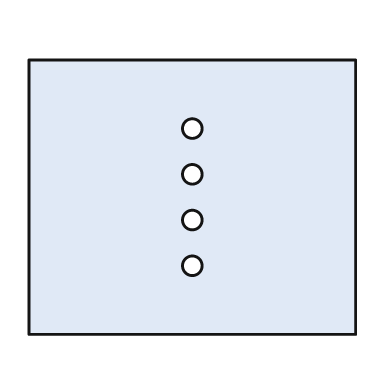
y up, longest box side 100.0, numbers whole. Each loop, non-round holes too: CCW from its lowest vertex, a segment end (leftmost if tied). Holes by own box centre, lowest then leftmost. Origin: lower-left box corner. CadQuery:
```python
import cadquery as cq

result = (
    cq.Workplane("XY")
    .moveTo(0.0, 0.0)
    .lineTo(100.0, 0.0)
    .lineTo(100.0, 84.0)
    .lineTo(0.0, 84.0)
    .close()
    .moveTo(50.0, 21.0)
    .circle(3.0)
    .moveTo(50.0, 35.0)
    .circle(3.0)
    .moveTo(50.0, 49.0)
    .circle(3.0)
    .moveTo(50.0, 63.0)
    .circle(3.0)
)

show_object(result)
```